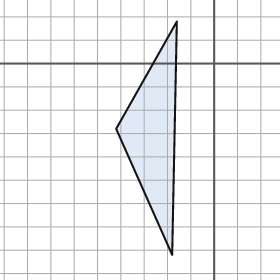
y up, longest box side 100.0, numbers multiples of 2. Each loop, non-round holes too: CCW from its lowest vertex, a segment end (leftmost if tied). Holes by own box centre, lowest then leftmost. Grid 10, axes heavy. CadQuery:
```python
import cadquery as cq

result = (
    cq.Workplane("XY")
    .moveTo(-18.0, -82.0)
    .lineTo(-16.0, 18.0)
    .lineTo(-42.0, -28.0)
    .close()
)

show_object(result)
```